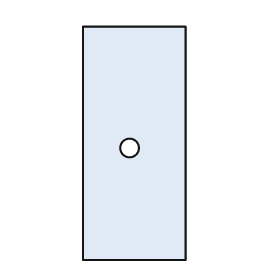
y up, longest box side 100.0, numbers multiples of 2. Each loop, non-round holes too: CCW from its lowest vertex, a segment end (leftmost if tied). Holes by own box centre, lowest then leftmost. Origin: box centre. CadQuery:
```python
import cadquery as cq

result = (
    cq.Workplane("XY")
    .moveTo(-22.0, -50.0)
    .lineTo(22.0, -50.0)
    .lineTo(22.0, 50.0)
    .lineTo(-22.0, 50.0)
    .close()
    .moveTo(-2.0, -2.0)
    .circle(4.0)
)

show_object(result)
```